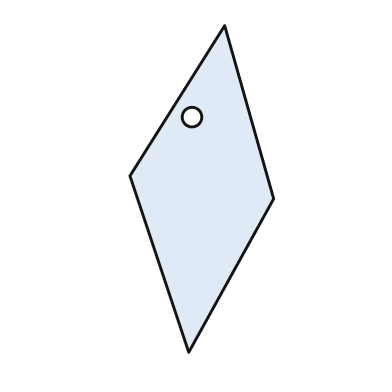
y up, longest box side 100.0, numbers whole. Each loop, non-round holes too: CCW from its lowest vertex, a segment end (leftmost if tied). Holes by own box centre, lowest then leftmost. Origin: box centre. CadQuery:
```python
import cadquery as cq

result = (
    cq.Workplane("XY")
    .moveTo(-4.0, -50.0)
    .lineTo(22.0, -3.0)
    .lineTo(7.0, 50.0)
    .lineTo(-22.0, 4.0)
    .close()
    .moveTo(-3.0, 22.0)
    .circle(3.0)
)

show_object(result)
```